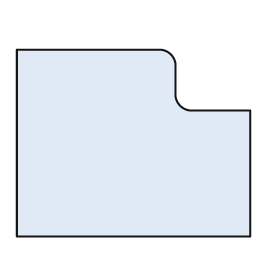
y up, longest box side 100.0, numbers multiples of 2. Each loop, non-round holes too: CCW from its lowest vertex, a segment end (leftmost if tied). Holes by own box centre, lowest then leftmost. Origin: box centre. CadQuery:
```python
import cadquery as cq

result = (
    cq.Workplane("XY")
    .moveTo(-50.0, -40.0)
    .lineTo(50.0, -40.0)
    .lineTo(50.0, 14.0)
    .lineTo(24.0, 14.0)
    .threePointArc((20.0, 16.0), (18.0, 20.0))
    .lineTo(18.0, 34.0)
    .threePointArc((16.0, 38.0), (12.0, 40.0))
    .lineTo(-50.0, 40.0)
    .close()
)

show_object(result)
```